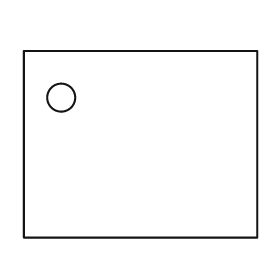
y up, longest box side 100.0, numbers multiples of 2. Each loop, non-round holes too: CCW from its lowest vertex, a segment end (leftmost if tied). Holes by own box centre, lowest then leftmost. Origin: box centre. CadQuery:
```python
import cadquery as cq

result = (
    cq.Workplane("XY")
    .moveTo(-50.0, -40.0)
    .lineTo(50.0, -40.0)
    .lineTo(50.0, 40.0)
    .lineTo(-50.0, 40.0)
    .close()
    .moveTo(-34.0, 20.0)
    .circle(6.0)
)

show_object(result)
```